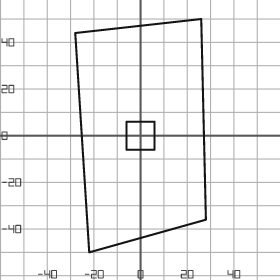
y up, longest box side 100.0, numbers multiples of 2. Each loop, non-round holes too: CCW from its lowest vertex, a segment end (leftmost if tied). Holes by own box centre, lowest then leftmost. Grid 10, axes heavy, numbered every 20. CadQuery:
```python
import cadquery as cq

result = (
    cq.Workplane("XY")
    .moveTo(-22.0, -50.0)
    .lineTo(28.0, -36.0)
    .lineTo(26.0, 50.0)
    .lineTo(-28.0, 44.0)
    .close()
    .moveTo(-6.0, -6.0)
    .lineTo(6.0, -6.0)
    .lineTo(6.0, 6.0)
    .lineTo(-6.0, 6.0)
    .close()
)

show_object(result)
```